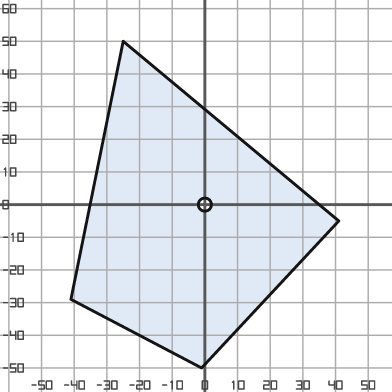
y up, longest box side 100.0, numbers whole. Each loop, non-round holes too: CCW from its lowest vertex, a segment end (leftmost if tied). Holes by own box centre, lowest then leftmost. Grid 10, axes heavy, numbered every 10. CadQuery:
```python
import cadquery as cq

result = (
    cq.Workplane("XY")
    .moveTo(-1.0, -50.0)
    .lineTo(41.0, -5.0)
    .lineTo(-25.0, 50.0)
    .lineTo(-41.0, -29.0)
    .close()
    .moveTo(0.0, 0.0)
    .circle(2.0)
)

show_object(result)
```